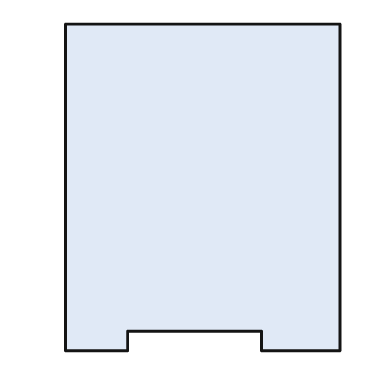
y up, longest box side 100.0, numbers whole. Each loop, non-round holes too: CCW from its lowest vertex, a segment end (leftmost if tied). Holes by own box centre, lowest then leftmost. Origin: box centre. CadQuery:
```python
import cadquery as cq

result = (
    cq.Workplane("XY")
    .moveTo(-42.0, -50.0)
    .lineTo(-23.0, -50.0)
    .lineTo(-23.0, -44.0)
    .lineTo(18.0, -44.0)
    .lineTo(18.0, -50.0)
    .lineTo(42.0, -50.0)
    .lineTo(42.0, 50.0)
    .lineTo(-42.0, 50.0)
    .close()
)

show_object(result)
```